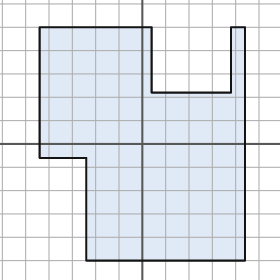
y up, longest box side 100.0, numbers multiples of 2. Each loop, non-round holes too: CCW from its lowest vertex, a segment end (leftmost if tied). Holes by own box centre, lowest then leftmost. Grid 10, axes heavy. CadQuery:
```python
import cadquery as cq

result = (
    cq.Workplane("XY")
    .moveTo(-24.0, -50.0)
    .lineTo(44.0, -50.0)
    .lineTo(44.0, 50.0)
    .lineTo(38.0, 50.0)
    .lineTo(38.0, 22.0)
    .lineTo(4.0, 22.0)
    .lineTo(4.0, 50.0)
    .lineTo(-44.0, 50.0)
    .lineTo(-44.0, -6.0)
    .lineTo(-24.0, -6.0)
    .close()
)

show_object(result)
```